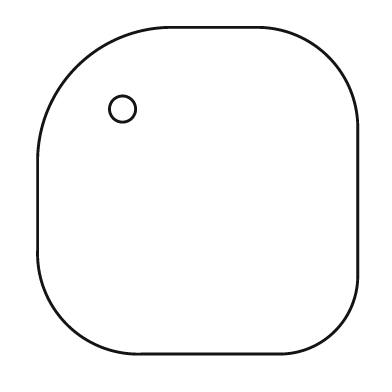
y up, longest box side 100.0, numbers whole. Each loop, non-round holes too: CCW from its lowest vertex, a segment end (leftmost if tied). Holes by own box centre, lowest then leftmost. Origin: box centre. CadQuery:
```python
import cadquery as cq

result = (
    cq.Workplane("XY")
    .moveTo(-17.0, -50.0)
    .lineTo(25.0, -50.0)
    .threePointArc((42.0, -43.0), (49.0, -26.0))
    .lineTo(49.0, 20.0)
    .threePointArc((40.0, 41.0), (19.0, 50.0))
    .lineTo(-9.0, 50.0)
    .threePointArc((-37.0, 38.0), (-49.0, 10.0))
    .lineTo(-49.0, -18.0)
    .threePointArc((-40.0, -41.0), (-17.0, -50.0))
    .close()
    .moveTo(-23.0, 25.0)
    .circle(4.0)
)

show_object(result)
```